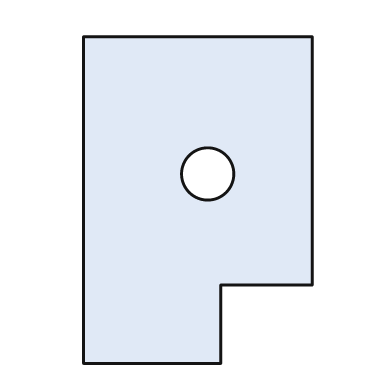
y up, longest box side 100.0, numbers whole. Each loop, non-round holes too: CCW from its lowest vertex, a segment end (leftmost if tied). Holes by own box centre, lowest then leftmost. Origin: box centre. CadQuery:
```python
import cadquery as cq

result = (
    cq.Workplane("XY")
    .moveTo(-35.0, -50.0)
    .lineTo(7.0, -50.0)
    .lineTo(7.0, -26.0)
    .lineTo(35.0, -26.0)
    .lineTo(35.0, 50.0)
    .lineTo(-35.0, 50.0)
    .close()
    .moveTo(3.0, 8.0)
    .circle(8.0)
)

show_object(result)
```